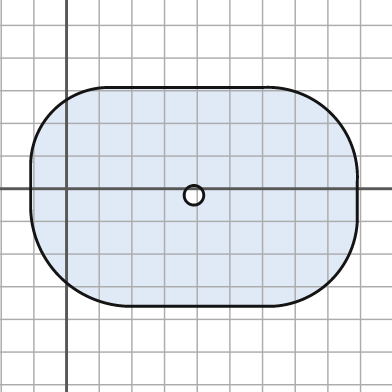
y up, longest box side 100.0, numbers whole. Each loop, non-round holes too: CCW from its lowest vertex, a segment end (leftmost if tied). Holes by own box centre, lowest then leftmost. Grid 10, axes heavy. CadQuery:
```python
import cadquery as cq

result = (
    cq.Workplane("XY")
    .moveTo(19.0, -36.0)
    .lineTo(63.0, -36.0)
    .threePointArc((81.0, -28.0), (89.0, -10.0))
    .lineTo(89.0, 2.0)
    .threePointArc((81.0, 23.0), (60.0, 31.0))
    .lineTo(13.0, 31.0)
    .threePointArc((-4.0, 24.0), (-11.0, 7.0))
    .lineTo(-11.0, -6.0)
    .threePointArc((-2.0, -27.0), (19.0, -36.0))
    .close()
    .moveTo(39.0, -2.0)
    .circle(3.0)
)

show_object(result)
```